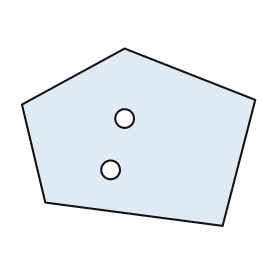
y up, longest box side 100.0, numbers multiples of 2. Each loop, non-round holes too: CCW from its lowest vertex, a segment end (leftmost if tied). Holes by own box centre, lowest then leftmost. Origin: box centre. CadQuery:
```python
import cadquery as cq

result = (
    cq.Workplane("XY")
    .moveTo(36.0, -38.0)
    .lineTo(50.0, 16.0)
    .lineTo(-6.0, 38.0)
    .lineTo(-50.0, 14.0)
    .lineTo(-40.0, -28.0)
    .close()
    .moveTo(-12.0, -14.0)
    .circle(4.0)
    .moveTo(-6.0, 8.0)
    .circle(4.0)
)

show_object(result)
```